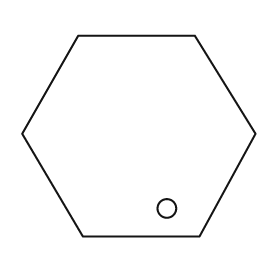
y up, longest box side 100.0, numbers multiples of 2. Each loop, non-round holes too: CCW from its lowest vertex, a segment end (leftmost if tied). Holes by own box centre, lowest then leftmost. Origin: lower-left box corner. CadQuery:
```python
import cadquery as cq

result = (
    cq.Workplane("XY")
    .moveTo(26.0, 0.0)
    .lineTo(76.0, 0.0)
    .lineTo(100.0, 44.0)
    .lineTo(74.0, 86.0)
    .lineTo(24.0, 86.0)
    .lineTo(0.0, 44.0)
    .close()
    .moveTo(62.0, 12.0)
    .circle(4.0)
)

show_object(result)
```